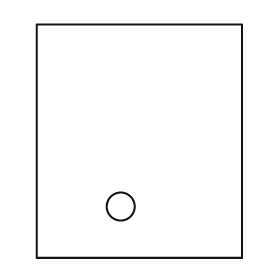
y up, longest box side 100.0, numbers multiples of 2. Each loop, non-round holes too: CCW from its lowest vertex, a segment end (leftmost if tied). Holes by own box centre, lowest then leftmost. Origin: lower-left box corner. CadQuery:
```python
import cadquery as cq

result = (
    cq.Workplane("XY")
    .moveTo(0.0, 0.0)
    .lineTo(88.0, 0.0)
    .lineTo(88.0, 100.0)
    .lineTo(0.0, 100.0)
    .close()
    .moveTo(36.0, 22.0)
    .circle(6.0)
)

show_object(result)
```